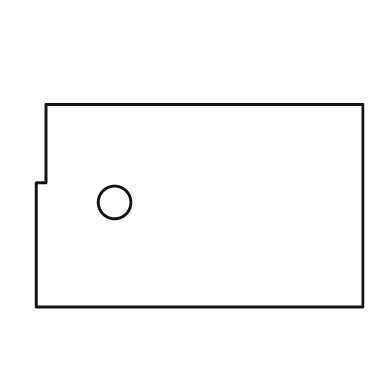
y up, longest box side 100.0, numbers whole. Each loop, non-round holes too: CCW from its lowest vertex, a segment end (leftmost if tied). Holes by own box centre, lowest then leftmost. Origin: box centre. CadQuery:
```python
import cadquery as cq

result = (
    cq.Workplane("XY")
    .moveTo(-50.0, -31.0)
    .lineTo(50.0, -31.0)
    .lineTo(50.0, 31.0)
    .lineTo(-47.0, 31.0)
    .lineTo(-47.0, 7.0)
    .lineTo(-50.0, 7.0)
    .close()
    .moveTo(-26.0, 1.0)
    .circle(5.0)
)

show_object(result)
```